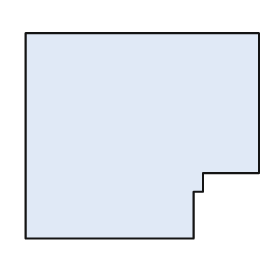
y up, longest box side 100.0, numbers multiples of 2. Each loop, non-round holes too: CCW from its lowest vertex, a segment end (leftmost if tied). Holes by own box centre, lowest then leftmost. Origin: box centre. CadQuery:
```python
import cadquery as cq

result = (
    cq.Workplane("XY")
    .moveTo(-50.0, -44.0)
    .lineTo(22.0, -44.0)
    .lineTo(22.0, -24.0)
    .lineTo(26.0, -24.0)
    .lineTo(26.0, -16.0)
    .lineTo(50.0, -16.0)
    .lineTo(50.0, 44.0)
    .lineTo(-50.0, 44.0)
    .close()
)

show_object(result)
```